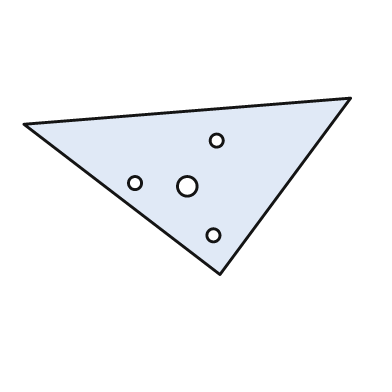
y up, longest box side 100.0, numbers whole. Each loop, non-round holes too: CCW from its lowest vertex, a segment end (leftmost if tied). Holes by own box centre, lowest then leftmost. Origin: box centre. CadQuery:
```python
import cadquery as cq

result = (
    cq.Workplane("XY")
    .moveTo(10.0, -27.0)
    .lineTo(50.0, 27.0)
    .lineTo(-50.0, 19.0)
    .close()
    .moveTo(8.0, -15.0)
    .circle(2.0)
    .moveTo(0.0, 0.0)
    .circle(3.0)
    .moveTo(-16.0, 1.0)
    .circle(2.0)
    .moveTo(9.0, 14.0)
    .circle(2.0)
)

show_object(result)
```